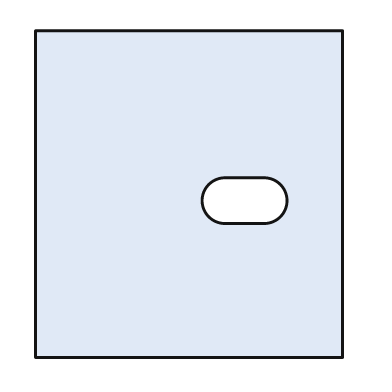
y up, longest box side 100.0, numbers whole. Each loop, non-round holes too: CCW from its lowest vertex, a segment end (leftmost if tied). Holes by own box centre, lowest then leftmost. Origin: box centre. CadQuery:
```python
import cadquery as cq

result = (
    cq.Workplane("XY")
    .moveTo(-47.0, -50.0)
    .lineTo(47.0, -50.0)
    .lineTo(47.0, 50.0)
    .lineTo(-47.0, 50.0)
    .close()
    .moveTo(11.0, -9.0)
    .lineTo(23.0, -9.0)
    .threePointArc((30.0, -2.0), (23.0, 5.0))
    .lineTo(11.0, 5.0)
    .threePointArc((4.0, -2.0), (11.0, -9.0))
    .close()
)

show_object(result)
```